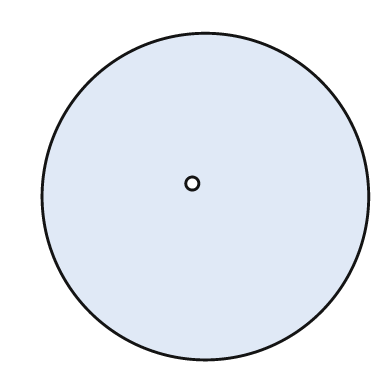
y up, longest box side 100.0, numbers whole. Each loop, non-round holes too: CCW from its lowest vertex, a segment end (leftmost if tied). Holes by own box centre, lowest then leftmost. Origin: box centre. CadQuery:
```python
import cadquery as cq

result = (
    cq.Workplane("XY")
    .moveTo(0.0, 0.0)
    .circle(50.0)
    .moveTo(-4.0, 4.0)
    .circle(2.0)
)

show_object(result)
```